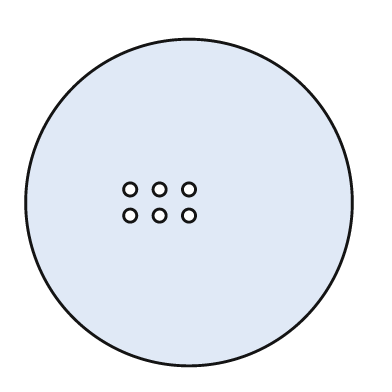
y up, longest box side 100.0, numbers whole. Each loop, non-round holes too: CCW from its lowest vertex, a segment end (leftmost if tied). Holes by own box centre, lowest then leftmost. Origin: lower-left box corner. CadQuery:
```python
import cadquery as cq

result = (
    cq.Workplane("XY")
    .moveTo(50.0, 50.0)
    .circle(50.0)
    .moveTo(32.0, 46.0)
    .circle(2.0)
    .moveTo(41.0, 46.0)
    .circle(2.0)
    .moveTo(50.0, 46.0)
    .circle(2.0)
    .moveTo(32.0, 54.0)
    .circle(2.0)
    .moveTo(41.0, 54.0)
    .circle(2.0)
    .moveTo(50.0, 54.0)
    .circle(2.0)
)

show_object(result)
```